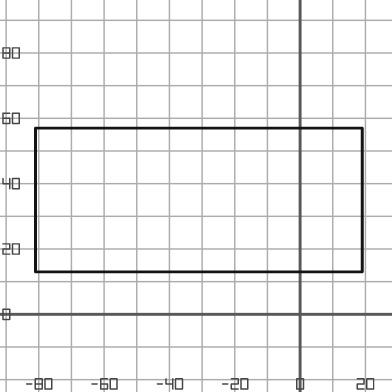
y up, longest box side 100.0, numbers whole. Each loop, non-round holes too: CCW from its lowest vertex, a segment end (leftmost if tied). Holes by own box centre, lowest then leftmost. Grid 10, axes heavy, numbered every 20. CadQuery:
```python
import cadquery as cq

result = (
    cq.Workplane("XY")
    .moveTo(-81.0, 13.0)
    .lineTo(19.0, 13.0)
    .lineTo(19.0, 57.0)
    .lineTo(-81.0, 57.0)
    .close()
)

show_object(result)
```